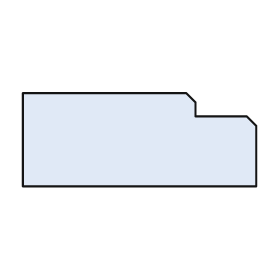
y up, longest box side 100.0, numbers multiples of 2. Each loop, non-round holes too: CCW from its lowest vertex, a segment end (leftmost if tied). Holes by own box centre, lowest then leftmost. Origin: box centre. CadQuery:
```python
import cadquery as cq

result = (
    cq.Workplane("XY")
    .moveTo(-50.0, -20.0)
    .lineTo(50.0, -20.0)
    .lineTo(50.0, 6.0)
    .lineTo(46.0, 10.0)
    .lineTo(24.0, 10.0)
    .lineTo(24.0, 16.0)
    .lineTo(20.0, 20.0)
    .lineTo(-50.0, 20.0)
    .close()
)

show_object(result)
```